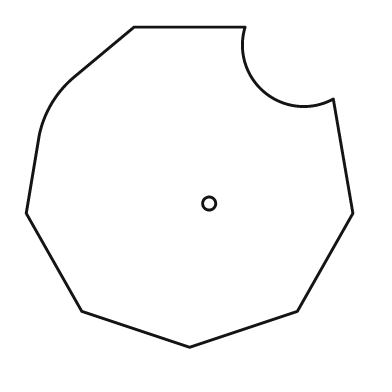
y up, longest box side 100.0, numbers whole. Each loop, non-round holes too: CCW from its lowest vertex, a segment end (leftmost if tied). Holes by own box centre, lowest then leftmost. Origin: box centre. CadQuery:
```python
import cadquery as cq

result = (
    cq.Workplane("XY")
    .moveTo(0.0, -49.0)
    .lineTo(33.0, -38.0)
    .lineTo(50.0, -8.0)
    .lineTo(44.0, 27.0)
    .threePointArc((23.0, 29.0), (17.0, 49.0))
    .lineTo(-17.0, 49.0)
    .lineTo(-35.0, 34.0)
    .threePointArc((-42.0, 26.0), (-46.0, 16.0))
    .lineTo(-50.0, -8.0)
    .lineTo(-33.0, -38.0)
    .close()
    .moveTo(6.0, -5.0)
    .circle(2.0)
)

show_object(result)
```